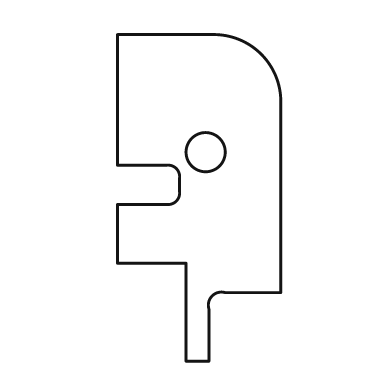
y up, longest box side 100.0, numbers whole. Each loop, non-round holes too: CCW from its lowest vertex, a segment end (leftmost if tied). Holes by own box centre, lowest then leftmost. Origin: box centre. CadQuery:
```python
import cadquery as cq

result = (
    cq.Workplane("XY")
    .moveTo(-4.0, -50.0)
    .lineTo(3.0, -50.0)
    .lineTo(3.0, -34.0)
    .threePointArc((4.0, -30.0), (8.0, -29.0))
    .lineTo(25.0, -29.0)
    .lineTo(25.0, 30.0)
    .threePointArc((19.0, 44.0), (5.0, 50.0))
    .lineTo(-25.0, 50.0)
    .lineTo(-25.0, 10.0)
    .lineTo(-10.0, 10.0)
    .threePointArc((-7.0, 9.0), (-6.0, 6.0))
    .lineTo(-6.0, 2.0)
    .threePointArc((-7.0, -1.0), (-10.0, -2.0))
    .lineTo(-25.0, -2.0)
    .lineTo(-25.0, -20.0)
    .lineTo(-4.0, -20.0)
    .close()
    .moveTo(2.0, 14.0)
    .circle(6.0)
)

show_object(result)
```